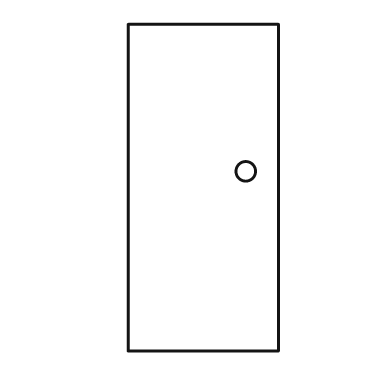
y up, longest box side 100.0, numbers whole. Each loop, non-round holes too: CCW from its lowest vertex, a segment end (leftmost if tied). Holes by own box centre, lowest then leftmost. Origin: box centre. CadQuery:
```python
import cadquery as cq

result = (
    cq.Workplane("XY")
    .moveTo(-23.0, -50.0)
    .lineTo(23.0, -50.0)
    .lineTo(23.0, 50.0)
    .lineTo(-23.0, 50.0)
    .close()
    .moveTo(13.0, 5.0)
    .circle(3.0)
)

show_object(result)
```